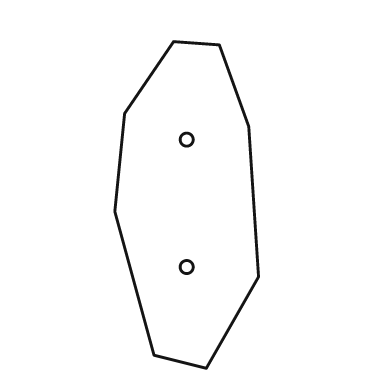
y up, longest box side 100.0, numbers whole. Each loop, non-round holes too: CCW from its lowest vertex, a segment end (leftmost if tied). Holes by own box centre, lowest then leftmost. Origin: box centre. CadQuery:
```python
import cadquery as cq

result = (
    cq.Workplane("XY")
    .moveTo(6.0, -50.0)
    .lineTo(22.0, -22.0)
    .lineTo(19.0, 24.0)
    .lineTo(10.0, 49.0)
    .lineTo(-4.0, 50.0)
    .lineTo(-19.0, 28.0)
    .lineTo(-22.0, -2.0)
    .lineTo(-10.0, -46.0)
    .close()
    .moveTo(0.0, -19.0)
    .circle(2.0)
    .moveTo(0.0, 20.0)
    .circle(2.0)
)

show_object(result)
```